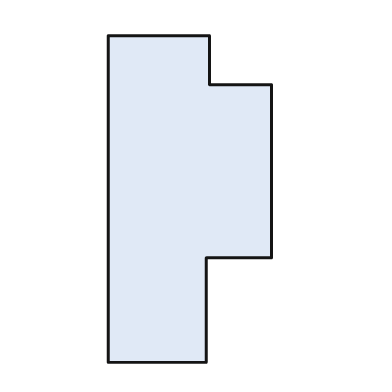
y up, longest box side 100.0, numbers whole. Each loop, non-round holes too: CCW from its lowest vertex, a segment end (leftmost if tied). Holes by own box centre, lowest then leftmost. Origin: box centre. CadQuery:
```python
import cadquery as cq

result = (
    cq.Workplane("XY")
    .moveTo(-25.0, -50.0)
    .lineTo(5.0, -50.0)
    .lineTo(5.0, -18.0)
    .lineTo(25.0, -18.0)
    .lineTo(25.0, 35.0)
    .lineTo(6.0, 35.0)
    .lineTo(6.0, 50.0)
    .lineTo(-25.0, 50.0)
    .close()
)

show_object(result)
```